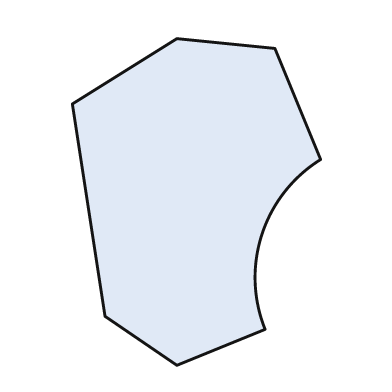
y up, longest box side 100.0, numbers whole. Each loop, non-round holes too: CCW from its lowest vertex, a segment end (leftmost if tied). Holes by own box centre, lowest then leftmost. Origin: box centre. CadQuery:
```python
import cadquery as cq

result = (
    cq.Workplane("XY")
    .moveTo(-6.0, -50.0)
    .lineTo(21.0, -39.0)
    .threePointArc((20.0, -10.0), (38.0, 13.0))
    .lineTo(24.0, 47.0)
    .lineTo(-6.0, 50.0)
    .lineTo(-38.0, 30.0)
    .lineTo(-28.0, -35.0)
    .close()
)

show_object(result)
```